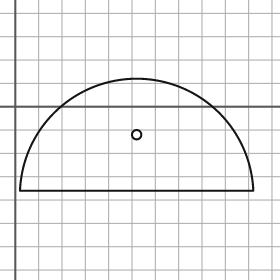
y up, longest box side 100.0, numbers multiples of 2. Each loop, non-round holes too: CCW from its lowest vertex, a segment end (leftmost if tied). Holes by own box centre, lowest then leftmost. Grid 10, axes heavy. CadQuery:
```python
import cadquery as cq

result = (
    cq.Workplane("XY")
    .moveTo(2.0, -36.0)
    .lineTo(102.0, -36.0)
    .threePointArc((52.0, 12.0), (2.0, -36.0))
    .close()
    .moveTo(52.0, -12.0)
    .circle(2.0)
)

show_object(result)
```